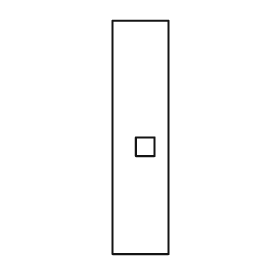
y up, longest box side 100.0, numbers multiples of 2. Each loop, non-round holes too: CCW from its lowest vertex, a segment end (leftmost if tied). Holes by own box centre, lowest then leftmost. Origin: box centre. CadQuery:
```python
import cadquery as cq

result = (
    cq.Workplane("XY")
    .moveTo(-12.0, -50.0)
    .lineTo(12.0, -50.0)
    .lineTo(12.0, 50.0)
    .lineTo(-12.0, 50.0)
    .close()
    .moveTo(-2.0, -8.0)
    .lineTo(6.0, -8.0)
    .lineTo(6.0, 0.0)
    .lineTo(-2.0, 0.0)
    .close()
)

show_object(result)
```